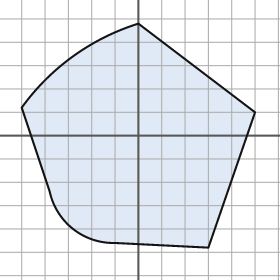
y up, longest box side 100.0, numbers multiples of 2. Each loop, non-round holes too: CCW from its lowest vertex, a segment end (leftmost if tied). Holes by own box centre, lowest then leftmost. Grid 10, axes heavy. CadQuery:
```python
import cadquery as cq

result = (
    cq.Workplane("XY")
    .moveTo(30.0, -48.0)
    .lineTo(50.0, 10.0)
    .lineTo(0.0, 48.0)
    .threePointArc((-28.0, 34.0), (-50.0, 12.0))
    .lineTo(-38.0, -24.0)
    .threePointArc((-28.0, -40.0), (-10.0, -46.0))
    .close()
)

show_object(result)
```